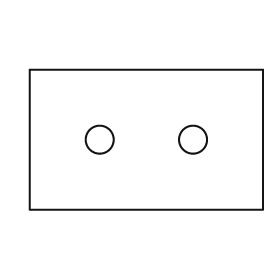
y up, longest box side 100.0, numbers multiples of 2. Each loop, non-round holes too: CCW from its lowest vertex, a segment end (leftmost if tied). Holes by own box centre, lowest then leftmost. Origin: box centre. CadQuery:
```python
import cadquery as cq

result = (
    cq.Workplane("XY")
    .moveTo(-50.0, -30.0)
    .lineTo(50.0, -30.0)
    .lineTo(50.0, 30.0)
    .lineTo(-50.0, 30.0)
    .close()
    .moveTo(-20.0, 0.0)
    .circle(6.0)
    .moveTo(20.0, 0.0)
    .circle(6.0)
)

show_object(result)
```